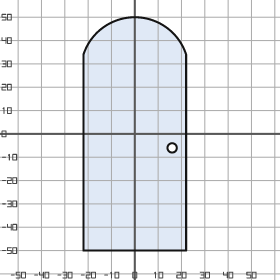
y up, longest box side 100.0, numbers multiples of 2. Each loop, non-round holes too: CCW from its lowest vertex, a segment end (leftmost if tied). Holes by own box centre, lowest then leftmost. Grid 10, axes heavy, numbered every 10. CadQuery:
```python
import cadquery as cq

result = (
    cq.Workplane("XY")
    .moveTo(-22.0, -50.0)
    .lineTo(22.0, -50.0)
    .lineTo(22.0, 34.0)
    .threePointArc((0.0, 50.0), (-22.0, 34.0))
    .close()
    .moveTo(16.0, -6.0)
    .circle(2.0)
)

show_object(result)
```